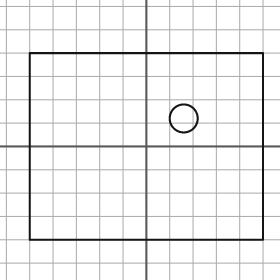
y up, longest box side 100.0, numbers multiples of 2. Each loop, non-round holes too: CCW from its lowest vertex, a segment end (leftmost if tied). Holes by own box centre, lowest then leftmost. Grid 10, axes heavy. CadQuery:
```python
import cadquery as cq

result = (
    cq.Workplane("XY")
    .moveTo(-50.0, -40.0)
    .lineTo(50.0, -40.0)
    .lineTo(50.0, 40.0)
    .lineTo(-50.0, 40.0)
    .close()
    .moveTo(16.0, 12.0)
    .circle(6.0)
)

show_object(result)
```